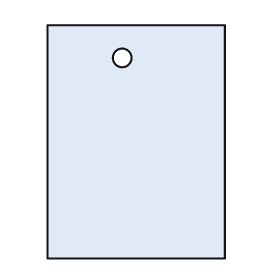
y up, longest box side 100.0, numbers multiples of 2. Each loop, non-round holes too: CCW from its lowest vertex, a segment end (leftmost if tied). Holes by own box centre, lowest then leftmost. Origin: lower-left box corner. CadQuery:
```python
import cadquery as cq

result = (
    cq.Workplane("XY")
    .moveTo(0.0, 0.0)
    .lineTo(76.0, 0.0)
    .lineTo(76.0, 100.0)
    .lineTo(0.0, 100.0)
    .close()
    .moveTo(32.0, 86.0)
    .circle(4.0)
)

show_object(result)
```